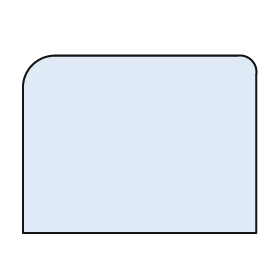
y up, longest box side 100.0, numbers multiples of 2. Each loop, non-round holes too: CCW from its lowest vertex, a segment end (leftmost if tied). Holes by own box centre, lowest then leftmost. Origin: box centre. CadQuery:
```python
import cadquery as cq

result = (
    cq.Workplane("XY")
    .moveTo(-50.0, -38.0)
    .lineTo(50.0, -38.0)
    .lineTo(50.0, 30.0)
    .threePointArc((48.0, 36.0), (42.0, 38.0))
    .lineTo(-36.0, 38.0)
    .threePointArc((-46.0, 34.0), (-50.0, 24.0))
    .close()
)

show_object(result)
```